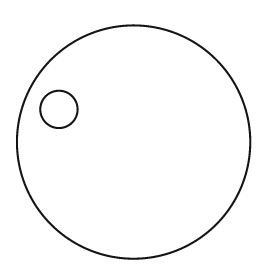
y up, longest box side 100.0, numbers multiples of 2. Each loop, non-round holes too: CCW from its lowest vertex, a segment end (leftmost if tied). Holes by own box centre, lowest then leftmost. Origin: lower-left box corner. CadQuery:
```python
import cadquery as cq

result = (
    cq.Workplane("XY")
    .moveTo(50.0, 50.0)
    .circle(50.0)
    .moveTo(18.0, 64.0)
    .circle(8.0)
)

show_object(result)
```